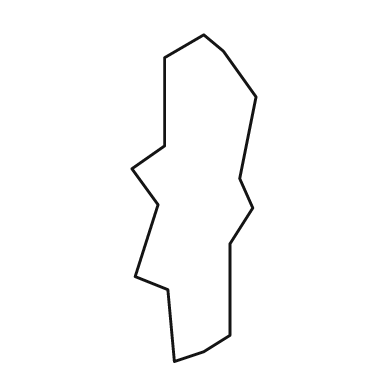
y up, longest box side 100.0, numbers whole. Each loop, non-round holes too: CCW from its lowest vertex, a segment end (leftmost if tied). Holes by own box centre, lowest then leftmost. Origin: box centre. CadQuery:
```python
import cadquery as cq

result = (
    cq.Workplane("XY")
    .moveTo(-6.0, -50.0)
    .lineTo(3.0, -47.0)
    .lineTo(11.0, -42.0)
    .lineTo(11.0, -14.0)
    .lineTo(18.0, -3.0)
    .lineTo(14.0, 6.0)
    .lineTo(19.0, 31.0)
    .lineTo(9.0, 45.0)
    .lineTo(3.0, 50.0)
    .lineTo(-9.0, 43.0)
    .lineTo(-9.0, 16.0)
    .lineTo(-19.0, 9.0)
    .lineTo(-11.0, -2.0)
    .lineTo(-18.0, -24.0)
    .lineTo(-8.0, -28.0)
    .close()
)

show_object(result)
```